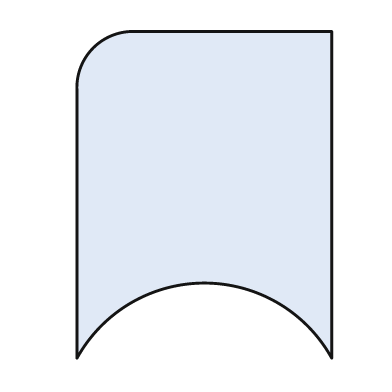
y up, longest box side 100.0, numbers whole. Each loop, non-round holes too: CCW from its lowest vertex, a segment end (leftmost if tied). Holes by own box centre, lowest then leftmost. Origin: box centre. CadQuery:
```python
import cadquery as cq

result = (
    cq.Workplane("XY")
    .moveTo(-39.0, -50.0)
    .threePointArc((0.0, -27.0), (39.0, -50.0))
    .lineTo(39.0, 50.0)
    .lineTo(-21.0, 50.0)
    .threePointArc((-34.0, 45.0), (-39.0, 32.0))
    .close()
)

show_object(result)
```